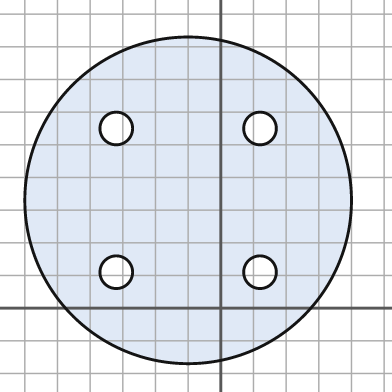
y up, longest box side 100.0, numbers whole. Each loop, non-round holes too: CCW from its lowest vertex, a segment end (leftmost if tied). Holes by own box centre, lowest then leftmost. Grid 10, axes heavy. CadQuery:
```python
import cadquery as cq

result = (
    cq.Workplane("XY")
    .moveTo(-10.0, 33.0)
    .circle(50.0)
    .moveTo(-32.0, 11.0)
    .circle(5.0)
    .moveTo(12.0, 11.0)
    .circle(5.0)
    .moveTo(-32.0, 55.0)
    .circle(5.0)
    .moveTo(12.0, 55.0)
    .circle(5.0)
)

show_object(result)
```